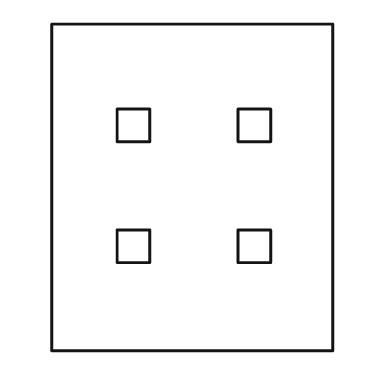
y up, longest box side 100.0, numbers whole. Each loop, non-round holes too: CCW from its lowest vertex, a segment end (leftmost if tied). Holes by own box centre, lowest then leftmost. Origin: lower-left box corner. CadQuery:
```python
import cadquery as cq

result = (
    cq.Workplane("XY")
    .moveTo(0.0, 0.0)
    .lineTo(86.0, 0.0)
    .lineTo(86.0, 100.0)
    .lineTo(0.0, 100.0)
    .close()
    .moveTo(20.0, 27.0)
    .lineTo(30.0, 27.0)
    .lineTo(30.0, 37.0)
    .lineTo(20.0, 37.0)
    .close()
    .moveTo(57.0, 27.0)
    .lineTo(67.0, 27.0)
    .lineTo(67.0, 37.0)
    .lineTo(57.0, 37.0)
    .close()
    .moveTo(20.0, 64.0)
    .lineTo(30.0, 64.0)
    .lineTo(30.0, 74.0)
    .lineTo(20.0, 74.0)
    .close()
    .moveTo(57.0, 64.0)
    .lineTo(67.0, 64.0)
    .lineTo(67.0, 74.0)
    .lineTo(57.0, 74.0)
    .close()
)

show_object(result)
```